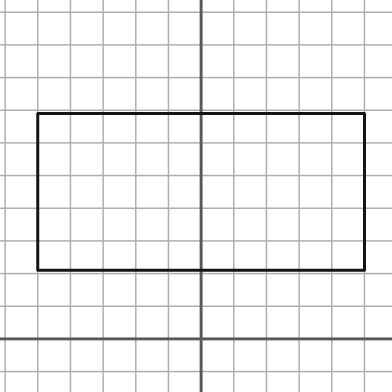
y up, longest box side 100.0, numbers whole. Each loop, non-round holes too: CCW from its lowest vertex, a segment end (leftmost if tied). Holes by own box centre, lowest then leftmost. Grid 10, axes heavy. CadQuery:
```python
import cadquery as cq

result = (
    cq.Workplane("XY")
    .moveTo(-50.0, 21.0)
    .lineTo(50.0, 21.0)
    .lineTo(50.0, 69.0)
    .lineTo(-50.0, 69.0)
    .close()
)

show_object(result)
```